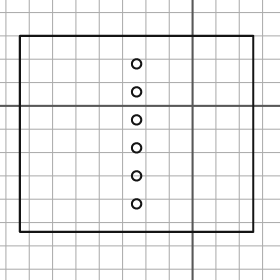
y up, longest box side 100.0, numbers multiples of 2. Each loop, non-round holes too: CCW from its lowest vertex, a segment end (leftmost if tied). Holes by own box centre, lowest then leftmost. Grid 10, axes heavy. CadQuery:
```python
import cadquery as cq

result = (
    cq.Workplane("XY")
    .moveTo(-74.0, -54.0)
    .lineTo(26.0, -54.0)
    .lineTo(26.0, 30.0)
    .lineTo(-74.0, 30.0)
    .close()
    .moveTo(-24.0, -42.0)
    .circle(2.0)
    .moveTo(-24.0, -30.0)
    .circle(2.0)
    .moveTo(-24.0, -18.0)
    .circle(2.0)
    .moveTo(-24.0, -6.0)
    .circle(2.0)
    .moveTo(-24.0, 6.0)
    .circle(2.0)
    .moveTo(-24.0, 18.0)
    .circle(2.0)
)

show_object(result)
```